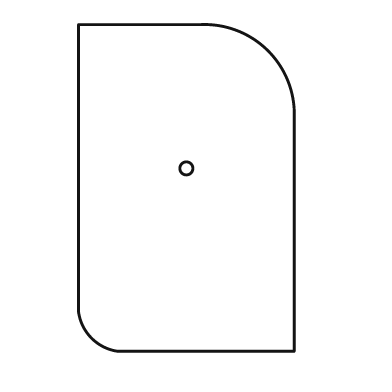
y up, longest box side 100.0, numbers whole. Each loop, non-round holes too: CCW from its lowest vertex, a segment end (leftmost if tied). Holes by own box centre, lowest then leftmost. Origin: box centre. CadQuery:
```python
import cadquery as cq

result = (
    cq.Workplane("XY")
    .moveTo(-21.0, -50.0)
    .lineTo(33.0, -50.0)
    .lineTo(33.0, 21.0)
    .threePointArc((25.0, 42.0), (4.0, 50.0))
    .lineTo(-33.0, 50.0)
    .lineTo(-33.0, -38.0)
    .threePointArc((-29.0, -46.0), (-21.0, -50.0))
    .close()
    .moveTo(0.0, 6.0)
    .circle(2.0)
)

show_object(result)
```